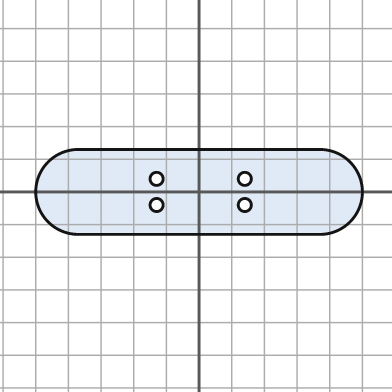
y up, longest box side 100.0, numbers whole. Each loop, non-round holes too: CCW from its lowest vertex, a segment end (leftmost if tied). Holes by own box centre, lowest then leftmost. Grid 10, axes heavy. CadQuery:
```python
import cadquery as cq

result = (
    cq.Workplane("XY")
    .moveTo(-37.0, -13.0)
    .lineTo(37.0, -13.0)
    .threePointArc((50.0, 0.0), (37.0, 13.0))
    .lineTo(-37.0, 13.0)
    .threePointArc((-50.0, 0.0), (-37.0, -13.0))
    .close()
    .moveTo(-13.0, -4.0)
    .circle(2.0)
    .moveTo(14.0, -4.0)
    .circle(2.0)
    .moveTo(-13.0, 4.0)
    .circle(2.0)
    .moveTo(14.0, 4.0)
    .circle(2.0)
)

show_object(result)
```